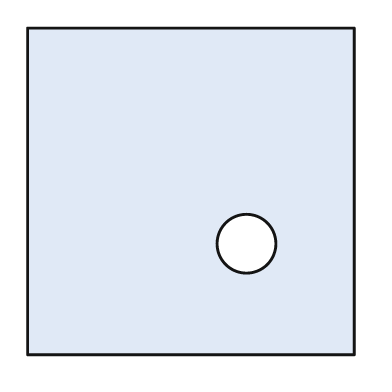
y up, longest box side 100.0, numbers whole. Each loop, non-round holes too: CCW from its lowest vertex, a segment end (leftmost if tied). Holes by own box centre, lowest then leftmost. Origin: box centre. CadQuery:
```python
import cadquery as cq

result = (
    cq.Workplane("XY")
    .moveTo(-50.0, -50.0)
    .lineTo(50.0, -50.0)
    .lineTo(50.0, 50.0)
    .lineTo(-50.0, 50.0)
    .close()
    .moveTo(17.0, -16.0)
    .circle(9.0)
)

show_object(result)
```